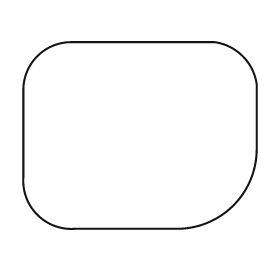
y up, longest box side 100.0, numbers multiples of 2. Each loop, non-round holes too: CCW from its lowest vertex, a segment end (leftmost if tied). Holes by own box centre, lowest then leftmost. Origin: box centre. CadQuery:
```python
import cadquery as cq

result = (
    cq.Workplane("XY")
    .moveTo(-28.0, -40.0)
    .lineTo(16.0, -40.0)
    .threePointArc((40.0, -30.0), (50.0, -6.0))
    .lineTo(50.0, 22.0)
    .threePointArc((44.0, 34.0), (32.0, 40.0))
    .lineTo(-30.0, 40.0)
    .threePointArc((-44.0, 34.0), (-50.0, 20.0))
    .lineTo(-50.0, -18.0)
    .threePointArc((-44.0, -34.0), (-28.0, -40.0))
    .close()
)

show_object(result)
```